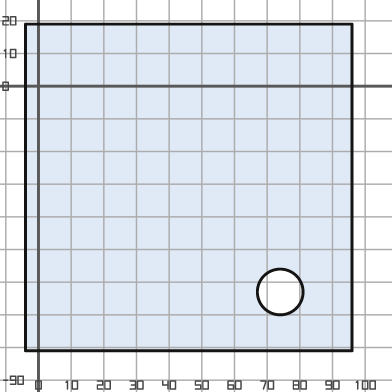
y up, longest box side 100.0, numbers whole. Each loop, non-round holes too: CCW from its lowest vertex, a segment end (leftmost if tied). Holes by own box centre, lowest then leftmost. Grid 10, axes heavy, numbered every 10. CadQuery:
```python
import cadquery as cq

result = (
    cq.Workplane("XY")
    .moveTo(-4.0, -81.0)
    .lineTo(96.0, -81.0)
    .lineTo(96.0, 19.0)
    .lineTo(-4.0, 19.0)
    .close()
    .moveTo(74.0, -63.0)
    .circle(7.0)
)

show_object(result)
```